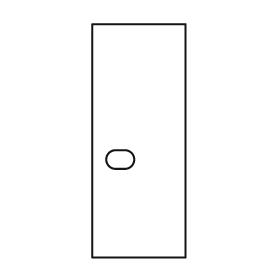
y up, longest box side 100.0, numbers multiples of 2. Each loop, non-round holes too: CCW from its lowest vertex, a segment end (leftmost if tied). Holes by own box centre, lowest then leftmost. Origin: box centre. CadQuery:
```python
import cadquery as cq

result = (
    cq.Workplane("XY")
    .moveTo(-20.0, -50.0)
    .lineTo(20.0, -50.0)
    .lineTo(20.0, 50.0)
    .lineTo(-20.0, 50.0)
    .close()
    .moveTo(-10.0, -12.0)
    .lineTo(-6.0, -12.0)
    .threePointArc((-2.0, -8.0), (-6.0, -4.0))
    .lineTo(-10.0, -4.0)
    .threePointArc((-14.0, -8.0), (-10.0, -12.0))
    .close()
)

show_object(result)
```